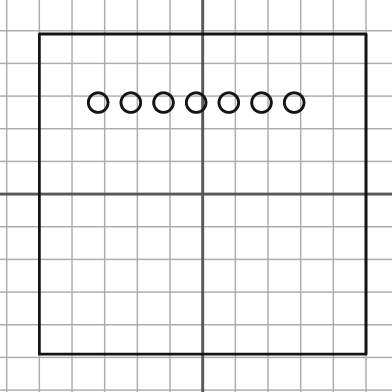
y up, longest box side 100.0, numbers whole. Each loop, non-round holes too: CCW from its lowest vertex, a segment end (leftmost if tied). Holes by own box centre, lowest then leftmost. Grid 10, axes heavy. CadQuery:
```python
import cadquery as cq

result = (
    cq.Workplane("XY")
    .moveTo(-50.0, -49.0)
    .lineTo(50.0, -49.0)
    .lineTo(50.0, 49.0)
    .lineTo(-50.0, 49.0)
    .close()
    .moveTo(-32.0, 28.0)
    .circle(3.0)
    .moveTo(-22.0, 28.0)
    .circle(3.0)
    .moveTo(-12.0, 28.0)
    .circle(3.0)
    .moveTo(-2.0, 28.0)
    .circle(3.0)
    .moveTo(8.0, 28.0)
    .circle(3.0)
    .moveTo(18.0, 28.0)
    .circle(3.0)
    .moveTo(28.0, 28.0)
    .circle(3.0)
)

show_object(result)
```